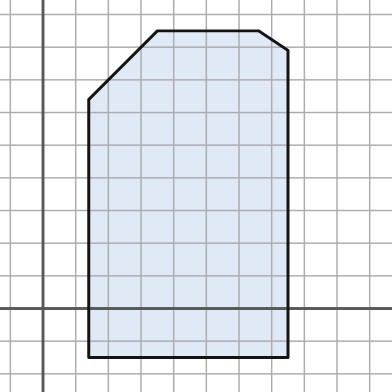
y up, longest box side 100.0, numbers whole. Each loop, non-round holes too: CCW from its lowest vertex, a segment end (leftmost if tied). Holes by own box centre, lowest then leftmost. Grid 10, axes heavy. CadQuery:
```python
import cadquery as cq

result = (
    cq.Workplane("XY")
    .moveTo(14.0, -15.0)
    .lineTo(75.0, -15.0)
    .lineTo(75.0, 79.0)
    .lineTo(66.0, 85.0)
    .lineTo(35.0, 85.0)
    .lineTo(14.0, 64.0)
    .close()
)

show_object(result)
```